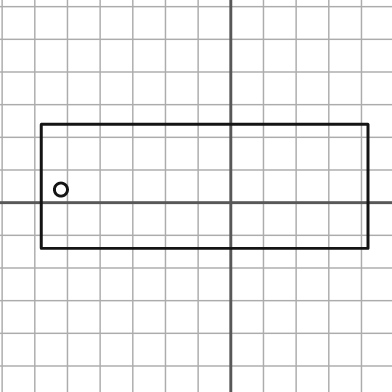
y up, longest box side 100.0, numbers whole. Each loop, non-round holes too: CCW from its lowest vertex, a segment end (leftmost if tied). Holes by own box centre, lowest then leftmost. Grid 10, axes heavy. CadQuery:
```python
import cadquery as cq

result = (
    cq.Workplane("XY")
    .moveTo(-58.0, -14.0)
    .lineTo(42.0, -14.0)
    .lineTo(42.0, 24.0)
    .lineTo(-58.0, 24.0)
    .close()
    .moveTo(-52.0, 4.0)
    .circle(2.0)
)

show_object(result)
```